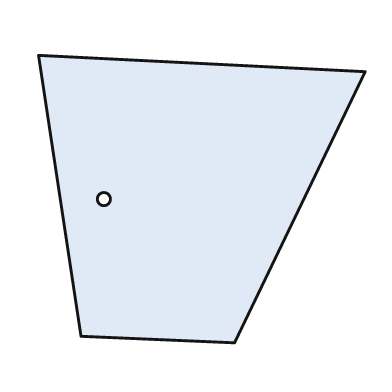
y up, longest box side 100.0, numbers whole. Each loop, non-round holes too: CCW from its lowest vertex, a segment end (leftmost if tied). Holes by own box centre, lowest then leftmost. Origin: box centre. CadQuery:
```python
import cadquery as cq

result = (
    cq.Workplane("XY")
    .moveTo(10.0, -44.0)
    .lineTo(50.0, 39.0)
    .lineTo(-50.0, 44.0)
    .lineTo(-37.0, -42.0)
    .close()
    .moveTo(-30.0, 0.0)
    .circle(2.0)
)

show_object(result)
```